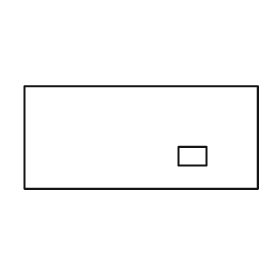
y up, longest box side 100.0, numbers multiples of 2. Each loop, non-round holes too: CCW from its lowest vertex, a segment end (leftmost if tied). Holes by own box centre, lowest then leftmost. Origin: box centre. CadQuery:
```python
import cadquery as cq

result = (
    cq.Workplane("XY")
    .moveTo(-50.0, -22.0)
    .lineTo(50.0, -22.0)
    .lineTo(50.0, 22.0)
    .lineTo(-50.0, 22.0)
    .close()
    .moveTo(16.0, -12.0)
    .lineTo(28.0, -12.0)
    .lineTo(28.0, -4.0)
    .lineTo(16.0, -4.0)
    .close()
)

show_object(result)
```